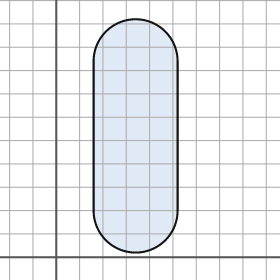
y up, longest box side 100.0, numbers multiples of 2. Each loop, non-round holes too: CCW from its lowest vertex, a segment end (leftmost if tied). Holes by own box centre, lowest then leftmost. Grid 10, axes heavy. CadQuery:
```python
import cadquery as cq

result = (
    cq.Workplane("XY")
    .moveTo(16.0, 20.0)
    .threePointArc((34.0, 2.0), (52.0, 20.0))
    .lineTo(52.0, 84.0)
    .threePointArc((34.0, 102.0), (16.0, 84.0))
    .close()
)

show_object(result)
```